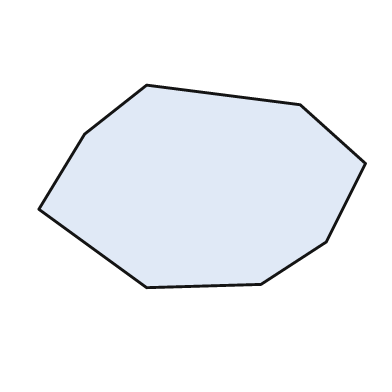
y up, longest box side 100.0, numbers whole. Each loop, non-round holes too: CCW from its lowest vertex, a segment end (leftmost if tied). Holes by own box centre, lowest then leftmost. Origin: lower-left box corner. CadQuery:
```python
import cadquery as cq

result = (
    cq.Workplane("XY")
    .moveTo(33.0, 0.0)
    .lineTo(68.0, 1.0)
    .lineTo(88.0, 14.0)
    .lineTo(100.0, 38.0)
    .lineTo(80.0, 56.0)
    .lineTo(33.0, 62.0)
    .lineTo(14.0, 47.0)
    .lineTo(0.0, 24.0)
    .close()
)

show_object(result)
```